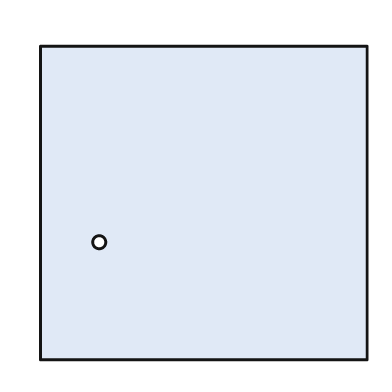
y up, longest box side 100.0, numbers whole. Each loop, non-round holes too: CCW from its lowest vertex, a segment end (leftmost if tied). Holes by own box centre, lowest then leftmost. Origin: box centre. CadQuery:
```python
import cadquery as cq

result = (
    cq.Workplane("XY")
    .moveTo(-50.0, -48.0)
    .lineTo(50.0, -48.0)
    .lineTo(50.0, 48.0)
    .lineTo(-50.0, 48.0)
    .close()
    .moveTo(-32.0, -12.0)
    .circle(2.0)
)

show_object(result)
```